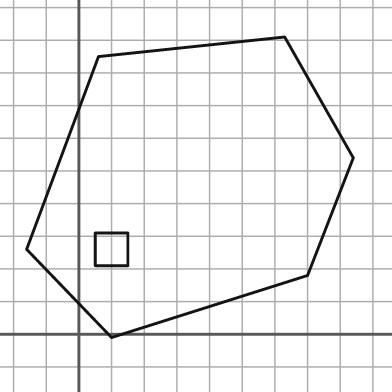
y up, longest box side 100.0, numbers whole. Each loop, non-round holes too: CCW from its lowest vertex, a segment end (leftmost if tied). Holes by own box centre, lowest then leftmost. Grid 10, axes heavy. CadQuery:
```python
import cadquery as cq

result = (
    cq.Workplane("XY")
    .moveTo(10.0, -1.0)
    .lineTo(70.0, 18.0)
    .lineTo(84.0, 54.0)
    .lineTo(63.0, 91.0)
    .lineTo(6.0, 85.0)
    .lineTo(-16.0, 26.0)
    .close()
    .moveTo(5.0, 21.0)
    .lineTo(15.0, 21.0)
    .lineTo(15.0, 31.0)
    .lineTo(5.0, 31.0)
    .close()
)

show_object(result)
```